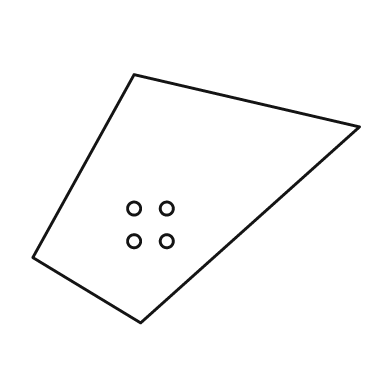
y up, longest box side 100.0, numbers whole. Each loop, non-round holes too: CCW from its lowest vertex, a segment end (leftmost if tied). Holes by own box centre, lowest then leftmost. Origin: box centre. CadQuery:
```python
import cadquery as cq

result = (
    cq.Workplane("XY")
    .moveTo(-17.0, -38.0)
    .lineTo(50.0, 22.0)
    .lineTo(-19.0, 38.0)
    .lineTo(-50.0, -18.0)
    .close()
    .moveTo(-19.0, -13.0)
    .circle(2.0)
    .moveTo(-9.0, -13.0)
    .circle(2.0)
    .moveTo(-19.0, -3.0)
    .circle(2.0)
    .moveTo(-9.0, -3.0)
    .circle(2.0)
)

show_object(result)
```